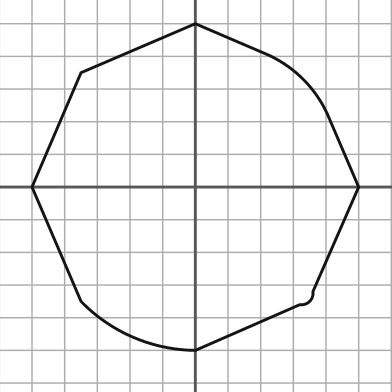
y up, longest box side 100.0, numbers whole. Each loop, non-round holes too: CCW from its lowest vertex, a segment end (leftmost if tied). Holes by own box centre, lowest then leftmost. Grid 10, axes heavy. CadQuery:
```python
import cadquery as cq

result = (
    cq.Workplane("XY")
    .moveTo(0.0, -50.0)
    .lineTo(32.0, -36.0)
    .threePointArc((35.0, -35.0), (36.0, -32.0))
    .lineTo(50.0, 0.0)
    .lineTo(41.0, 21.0)
    .threePointArc((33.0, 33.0), (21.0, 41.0))
    .lineTo(0.0, 50.0)
    .lineTo(-35.0, 35.0)
    .lineTo(-50.0, 0.0)
    .lineTo(-35.0, -35.0)
    .threePointArc((-19.0, -46.0), (0.0, -50.0))
    .close()
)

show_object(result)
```